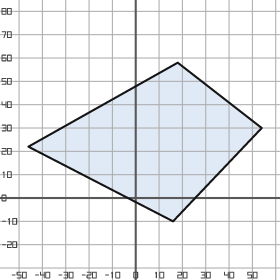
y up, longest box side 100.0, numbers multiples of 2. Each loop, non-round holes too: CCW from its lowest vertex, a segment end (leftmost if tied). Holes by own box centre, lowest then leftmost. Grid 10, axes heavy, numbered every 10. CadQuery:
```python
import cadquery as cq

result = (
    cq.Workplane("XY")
    .moveTo(16.0, -10.0)
    .lineTo(54.0, 30.0)
    .lineTo(18.0, 58.0)
    .lineTo(-46.0, 22.0)
    .close()
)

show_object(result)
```